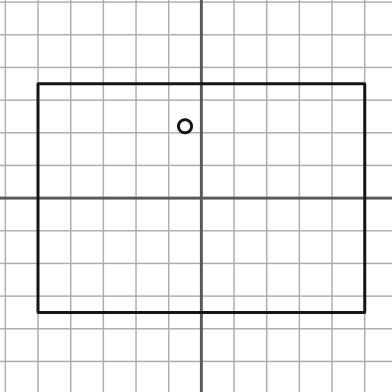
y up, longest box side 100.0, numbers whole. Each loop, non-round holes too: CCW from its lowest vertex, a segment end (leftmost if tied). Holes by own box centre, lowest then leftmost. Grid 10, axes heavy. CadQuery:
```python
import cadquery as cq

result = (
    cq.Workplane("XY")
    .moveTo(-50.0, -35.0)
    .lineTo(50.0, -35.0)
    .lineTo(50.0, 35.0)
    .lineTo(-50.0, 35.0)
    .close()
    .moveTo(-5.0, 22.0)
    .circle(2.0)
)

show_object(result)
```